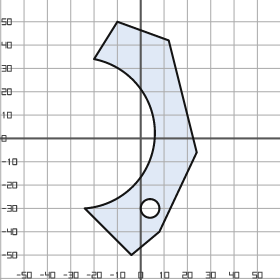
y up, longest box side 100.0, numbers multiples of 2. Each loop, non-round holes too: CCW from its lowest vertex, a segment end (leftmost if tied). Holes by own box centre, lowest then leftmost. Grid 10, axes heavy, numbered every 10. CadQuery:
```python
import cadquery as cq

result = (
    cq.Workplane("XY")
    .moveTo(-4.0, -50.0)
    .lineTo(8.0, -40.0)
    .lineTo(24.0, -6.0)
    .lineTo(12.0, 42.0)
    .lineTo(-10.0, 50.0)
    .lineTo(-20.0, 34.0)
    .threePointArc((6.0, 0.0), (-24.0, -30.0))
    .close()
    .moveTo(4.0, -30.0)
    .circle(4.0)
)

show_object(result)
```